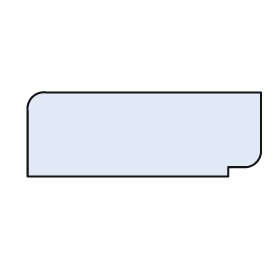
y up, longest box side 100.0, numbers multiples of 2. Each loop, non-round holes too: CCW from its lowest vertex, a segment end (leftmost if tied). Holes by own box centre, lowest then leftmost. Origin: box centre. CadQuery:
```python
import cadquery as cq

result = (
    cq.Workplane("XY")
    .moveTo(-50.0, -18.0)
    .lineTo(36.0, -18.0)
    .lineTo(36.0, -14.0)
    .lineTo(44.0, -14.0)
    .threePointArc((48.0, -12.0), (50.0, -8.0))
    .lineTo(50.0, 18.0)
    .lineTo(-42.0, 18.0)
    .threePointArc((-48.0, 16.0), (-50.0, 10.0))
    .close()
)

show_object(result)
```